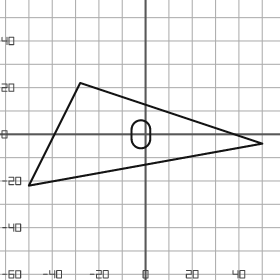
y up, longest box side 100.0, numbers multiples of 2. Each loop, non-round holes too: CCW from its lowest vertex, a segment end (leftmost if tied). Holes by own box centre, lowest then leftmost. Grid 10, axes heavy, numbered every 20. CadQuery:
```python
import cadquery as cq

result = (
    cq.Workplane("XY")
    .moveTo(-50.0, -22.0)
    .lineTo(50.0, -4.0)
    .lineTo(-28.0, 22.0)
    .close()
    .moveTo(-6.0, -2.0)
    .threePointArc((-2.0, -6.0), (2.0, -2.0))
    .lineTo(2.0, 2.0)
    .threePointArc((-2.0, 6.0), (-6.0, 2.0))
    .close()
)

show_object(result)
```